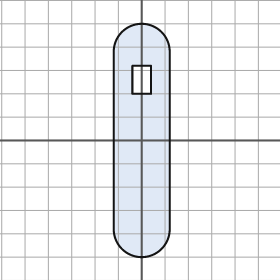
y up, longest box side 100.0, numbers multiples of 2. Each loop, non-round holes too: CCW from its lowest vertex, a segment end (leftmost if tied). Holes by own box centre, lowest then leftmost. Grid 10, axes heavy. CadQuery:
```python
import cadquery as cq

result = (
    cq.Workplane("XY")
    .moveTo(-12.0, -38.0)
    .threePointArc((0.0, -50.0), (12.0, -38.0))
    .lineTo(12.0, 38.0)
    .threePointArc((0.0, 50.0), (-12.0, 38.0))
    .close()
    .moveTo(-4.0, 20.0)
    .lineTo(4.0, 20.0)
    .lineTo(4.0, 32.0)
    .lineTo(-4.0, 32.0)
    .close()
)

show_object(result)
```